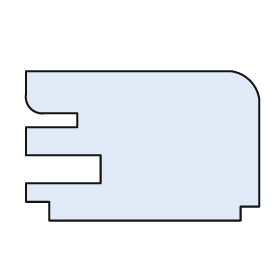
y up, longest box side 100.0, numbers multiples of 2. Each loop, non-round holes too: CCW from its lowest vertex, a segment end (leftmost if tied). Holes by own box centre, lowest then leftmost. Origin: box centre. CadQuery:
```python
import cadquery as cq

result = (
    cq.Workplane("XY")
    .moveTo(-40.0, -32.0)
    .lineTo(42.0, -32.0)
    .lineTo(42.0, -26.0)
    .lineTo(50.0, -26.0)
    .lineTo(50.0, 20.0)
    .threePointArc((46.0, 28.0), (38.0, 32.0))
    .lineTo(-50.0, 32.0)
    .lineTo(-50.0, 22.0)
    .threePointArc((-48.0, 16.0), (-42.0, 14.0))
    .lineTo(-28.0, 14.0)
    .lineTo(-28.0, 8.0)
    .lineTo(-50.0, 8.0)
    .lineTo(-50.0, -4.0)
    .lineTo(-18.0, -4.0)
    .lineTo(-18.0, -16.0)
    .lineTo(-50.0, -16.0)
    .lineTo(-50.0, -24.0)
    .lineTo(-40.0, -24.0)
    .close()
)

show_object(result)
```